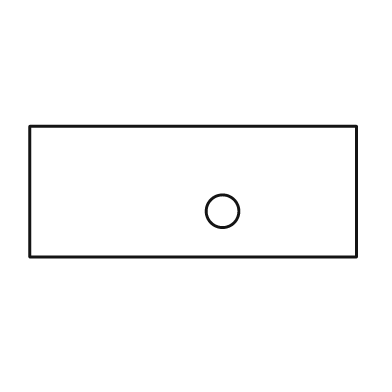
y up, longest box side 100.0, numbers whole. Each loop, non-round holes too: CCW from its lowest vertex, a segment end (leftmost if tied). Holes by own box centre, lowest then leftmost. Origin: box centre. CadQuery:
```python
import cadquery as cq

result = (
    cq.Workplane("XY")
    .moveTo(-50.0, -20.0)
    .lineTo(50.0, -20.0)
    .lineTo(50.0, 20.0)
    .lineTo(-50.0, 20.0)
    .close()
    .moveTo(9.0, -6.0)
    .circle(5.0)
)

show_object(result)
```